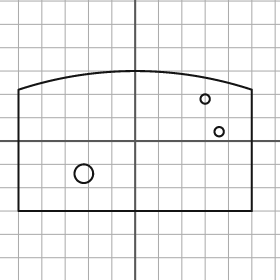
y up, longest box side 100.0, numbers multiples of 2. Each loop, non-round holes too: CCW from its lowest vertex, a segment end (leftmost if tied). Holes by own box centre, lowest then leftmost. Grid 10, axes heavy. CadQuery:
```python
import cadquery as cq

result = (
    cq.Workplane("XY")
    .moveTo(-50.0, -30.0)
    .lineTo(50.0, -30.0)
    .lineTo(50.0, 22.0)
    .threePointArc((0.0, 30.0), (-50.0, 22.0))
    .close()
    .moveTo(-22.0, -14.0)
    .circle(4.0)
    .moveTo(36.0, 4.0)
    .circle(2.0)
    .moveTo(30.0, 18.0)
    .circle(2.0)
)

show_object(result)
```